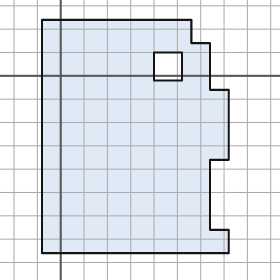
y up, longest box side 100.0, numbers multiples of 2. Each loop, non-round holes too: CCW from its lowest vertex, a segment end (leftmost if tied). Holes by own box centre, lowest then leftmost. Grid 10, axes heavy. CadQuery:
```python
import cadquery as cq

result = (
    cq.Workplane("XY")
    .moveTo(-8.0, -76.0)
    .lineTo(72.0, -76.0)
    .lineTo(72.0, -66.0)
    .lineTo(64.0, -66.0)
    .lineTo(64.0, -36.0)
    .lineTo(72.0, -36.0)
    .lineTo(72.0, -6.0)
    .lineTo(64.0, -6.0)
    .lineTo(64.0, 14.0)
    .lineTo(56.0, 14.0)
    .lineTo(56.0, 24.0)
    .lineTo(-8.0, 24.0)
    .close()
    .moveTo(40.0, -2.0)
    .lineTo(52.0, -2.0)
    .lineTo(52.0, 10.0)
    .lineTo(40.0, 10.0)
    .close()
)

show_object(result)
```